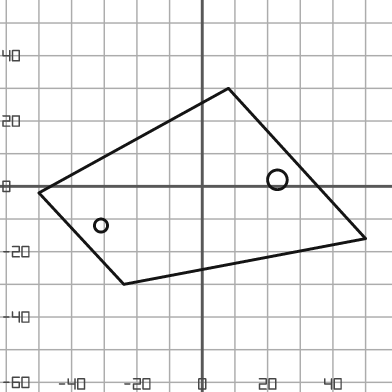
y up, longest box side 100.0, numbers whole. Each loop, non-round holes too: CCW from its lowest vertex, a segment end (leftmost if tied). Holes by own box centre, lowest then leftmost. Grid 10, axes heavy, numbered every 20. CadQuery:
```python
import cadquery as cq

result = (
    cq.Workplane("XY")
    .moveTo(-24.0, -30.0)
    .lineTo(50.0, -16.0)
    .lineTo(8.0, 30.0)
    .lineTo(-50.0, -2.0)
    .close()
    .moveTo(-31.0, -12.0)
    .circle(2.0)
    .moveTo(23.0, 2.0)
    .circle(3.0)
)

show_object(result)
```